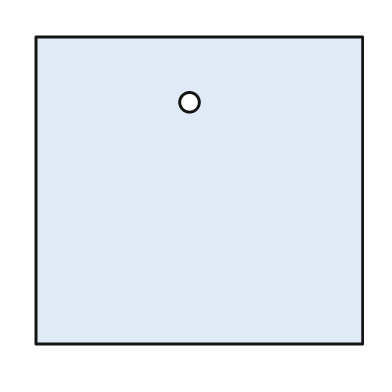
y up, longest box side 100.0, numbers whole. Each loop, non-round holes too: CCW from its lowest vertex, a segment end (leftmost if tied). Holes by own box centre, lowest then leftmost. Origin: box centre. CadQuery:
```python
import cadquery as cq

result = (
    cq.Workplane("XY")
    .moveTo(-50.0, -47.0)
    .lineTo(50.0, -47.0)
    .lineTo(50.0, 47.0)
    .lineTo(-50.0, 47.0)
    .close()
    .moveTo(-3.0, 27.0)
    .circle(3.0)
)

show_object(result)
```